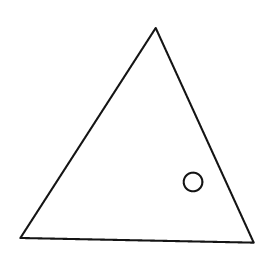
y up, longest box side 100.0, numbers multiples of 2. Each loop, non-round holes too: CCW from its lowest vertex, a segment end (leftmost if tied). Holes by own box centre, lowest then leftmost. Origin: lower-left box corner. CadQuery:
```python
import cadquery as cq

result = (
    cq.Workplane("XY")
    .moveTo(100.0, 0.0)
    .lineTo(58.0, 92.0)
    .lineTo(0.0, 2.0)
    .close()
    .moveTo(74.0, 26.0)
    .circle(4.0)
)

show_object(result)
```